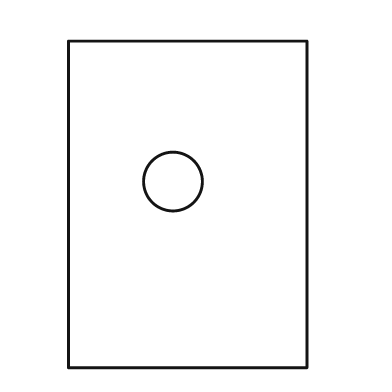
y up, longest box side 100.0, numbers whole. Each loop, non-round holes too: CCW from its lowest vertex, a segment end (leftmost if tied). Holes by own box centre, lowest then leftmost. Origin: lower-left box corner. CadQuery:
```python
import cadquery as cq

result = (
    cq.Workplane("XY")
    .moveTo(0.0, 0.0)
    .lineTo(73.0, 0.0)
    .lineTo(73.0, 100.0)
    .lineTo(0.0, 100.0)
    .close()
    .moveTo(32.0, 57.0)
    .circle(9.0)
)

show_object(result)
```